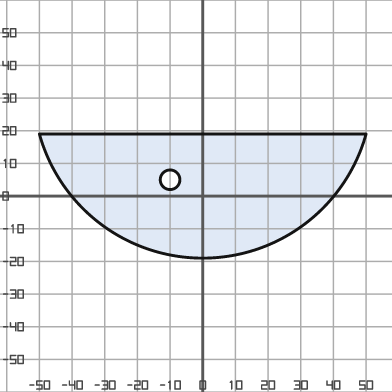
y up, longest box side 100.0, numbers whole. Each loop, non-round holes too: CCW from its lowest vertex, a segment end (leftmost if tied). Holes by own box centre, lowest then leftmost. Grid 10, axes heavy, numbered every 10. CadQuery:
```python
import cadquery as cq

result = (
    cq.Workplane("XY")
    .moveTo(-50.0, 19.0)
    .threePointArc((0.0, -19.0), (50.0, 19.0))
    .close()
    .moveTo(-10.0, 5.0)
    .circle(3.0)
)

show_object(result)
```